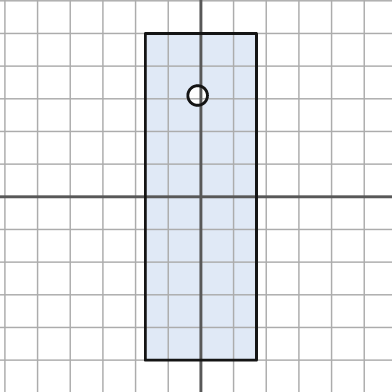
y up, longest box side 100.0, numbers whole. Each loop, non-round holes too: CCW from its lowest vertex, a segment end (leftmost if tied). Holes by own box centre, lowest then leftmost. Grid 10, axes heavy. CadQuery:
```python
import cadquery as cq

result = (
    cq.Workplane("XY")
    .moveTo(-17.0, -50.0)
    .lineTo(17.0, -50.0)
    .lineTo(17.0, 50.0)
    .lineTo(-17.0, 50.0)
    .close()
    .moveTo(-1.0, 31.0)
    .circle(3.0)
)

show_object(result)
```